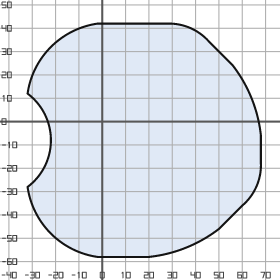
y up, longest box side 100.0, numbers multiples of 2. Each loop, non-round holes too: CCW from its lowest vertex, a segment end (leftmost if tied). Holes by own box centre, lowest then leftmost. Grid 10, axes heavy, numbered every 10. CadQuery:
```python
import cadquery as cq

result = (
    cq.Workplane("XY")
    .moveTo(-2.0, -58.0)
    .lineTo(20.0, -58.0)
    .threePointArc((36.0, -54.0), (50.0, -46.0))
    .lineTo(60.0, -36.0)
    .threePointArc((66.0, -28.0), (68.0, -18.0))
    .lineTo(68.0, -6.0)
    .threePointArc((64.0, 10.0), (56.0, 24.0))
    .lineTo(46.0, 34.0)
    .threePointArc((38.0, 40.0), (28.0, 42.0))
    .lineTo(-2.0, 42.0)
    .threePointArc((-22.0, 32.0), (-32.0, 12.0))
    .threePointArc((-22.0, -8.0), (-32.0, -28.0))
    .threePointArc((-22.0, -48.0), (-2.0, -58.0))
    .close()
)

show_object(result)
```